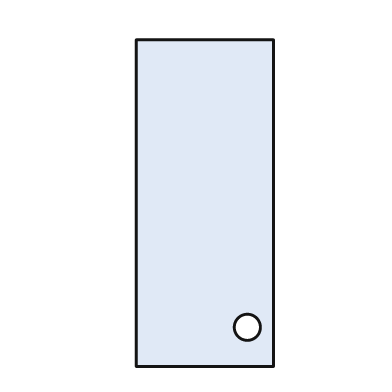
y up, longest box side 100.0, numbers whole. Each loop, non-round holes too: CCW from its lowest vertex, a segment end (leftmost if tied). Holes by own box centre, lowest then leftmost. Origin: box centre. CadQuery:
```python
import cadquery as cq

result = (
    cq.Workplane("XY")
    .moveTo(-21.0, -50.0)
    .lineTo(21.0, -50.0)
    .lineTo(21.0, 50.0)
    .lineTo(-21.0, 50.0)
    .close()
    .moveTo(13.0, -38.0)
    .circle(4.0)
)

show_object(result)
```